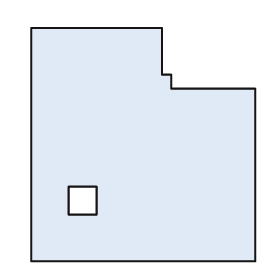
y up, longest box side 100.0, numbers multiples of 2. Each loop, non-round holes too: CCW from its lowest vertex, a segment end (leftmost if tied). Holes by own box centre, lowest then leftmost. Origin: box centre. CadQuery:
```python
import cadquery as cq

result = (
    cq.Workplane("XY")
    .moveTo(-48.0, -50.0)
    .lineTo(48.0, -50.0)
    .lineTo(48.0, 24.0)
    .lineTo(12.0, 24.0)
    .lineTo(12.0, 30.0)
    .lineTo(8.0, 30.0)
    .lineTo(8.0, 50.0)
    .lineTo(-48.0, 50.0)
    .close()
    .moveTo(-32.0, -30.0)
    .lineTo(-20.0, -30.0)
    .lineTo(-20.0, -18.0)
    .lineTo(-32.0, -18.0)
    .close()
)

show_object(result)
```